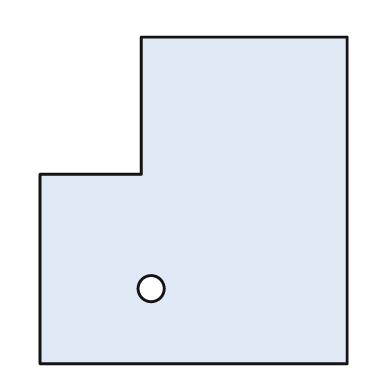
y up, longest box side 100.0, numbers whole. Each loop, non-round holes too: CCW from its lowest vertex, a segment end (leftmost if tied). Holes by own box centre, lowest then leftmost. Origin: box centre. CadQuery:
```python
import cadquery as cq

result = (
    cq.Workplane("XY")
    .moveTo(-47.0, -50.0)
    .lineTo(47.0, -50.0)
    .lineTo(47.0, 50.0)
    .lineTo(-16.0, 50.0)
    .lineTo(-16.0, 8.0)
    .lineTo(-47.0, 8.0)
    .close()
    .moveTo(-13.0, -27.0)
    .circle(4.0)
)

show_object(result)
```